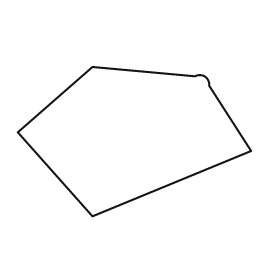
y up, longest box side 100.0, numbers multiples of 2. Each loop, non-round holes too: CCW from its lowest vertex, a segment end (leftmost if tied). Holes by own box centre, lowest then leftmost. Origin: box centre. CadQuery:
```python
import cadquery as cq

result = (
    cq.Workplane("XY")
    .moveTo(-18.0, -32.0)
    .lineTo(50.0, -4.0)
    .lineTo(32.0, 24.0)
    .threePointArc((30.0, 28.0), (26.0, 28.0))
    .lineTo(-18.0, 32.0)
    .lineTo(-50.0, 4.0)
    .close()
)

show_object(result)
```